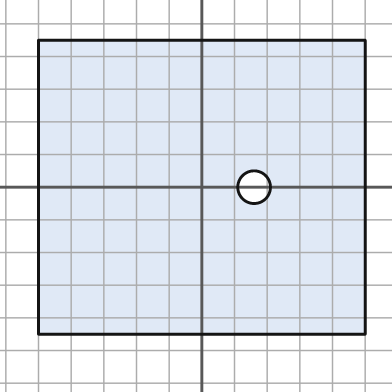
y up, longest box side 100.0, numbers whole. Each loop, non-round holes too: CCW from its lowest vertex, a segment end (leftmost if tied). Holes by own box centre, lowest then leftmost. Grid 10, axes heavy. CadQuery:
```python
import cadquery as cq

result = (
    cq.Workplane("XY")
    .moveTo(-50.0, -45.0)
    .lineTo(50.0, -45.0)
    .lineTo(50.0, 45.0)
    .lineTo(-50.0, 45.0)
    .close()
    .moveTo(16.0, 0.0)
    .circle(5.0)
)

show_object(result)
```